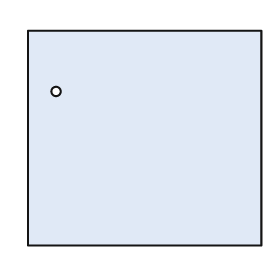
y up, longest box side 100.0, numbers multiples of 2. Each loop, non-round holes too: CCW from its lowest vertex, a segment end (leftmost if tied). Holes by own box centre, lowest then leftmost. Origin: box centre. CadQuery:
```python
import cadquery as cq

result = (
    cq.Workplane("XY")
    .moveTo(-50.0, -46.0)
    .lineTo(50.0, -46.0)
    .lineTo(50.0, 46.0)
    .lineTo(-50.0, 46.0)
    .close()
    .moveTo(-38.0, 20.0)
    .circle(2.0)
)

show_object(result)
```